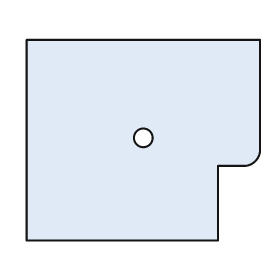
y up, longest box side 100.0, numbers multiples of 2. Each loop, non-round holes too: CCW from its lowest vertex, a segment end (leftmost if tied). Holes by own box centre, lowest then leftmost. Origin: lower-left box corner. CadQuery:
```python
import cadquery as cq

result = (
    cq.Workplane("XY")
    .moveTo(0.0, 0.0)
    .lineTo(82.0, 0.0)
    .lineTo(82.0, 32.0)
    .lineTo(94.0, 32.0)
    .threePointArc((98.0, 34.0), (100.0, 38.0))
    .lineTo(100.0, 86.0)
    .lineTo(0.0, 86.0)
    .close()
    .moveTo(50.0, 44.0)
    .circle(4.0)
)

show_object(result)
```